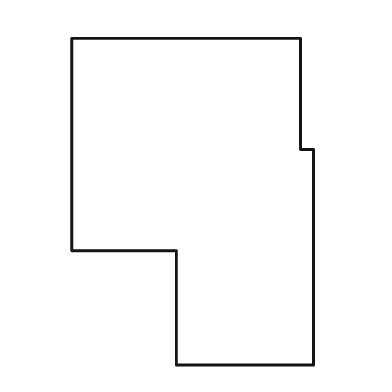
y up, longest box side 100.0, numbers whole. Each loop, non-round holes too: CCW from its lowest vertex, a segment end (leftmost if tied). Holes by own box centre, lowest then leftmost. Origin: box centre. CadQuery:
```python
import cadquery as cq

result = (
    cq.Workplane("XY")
    .moveTo(-5.0, -50.0)
    .lineTo(37.0, -50.0)
    .lineTo(37.0, 16.0)
    .lineTo(33.0, 16.0)
    .lineTo(33.0, 50.0)
    .lineTo(-37.0, 50.0)
    .lineTo(-37.0, -15.0)
    .lineTo(-5.0, -15.0)
    .close()
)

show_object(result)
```